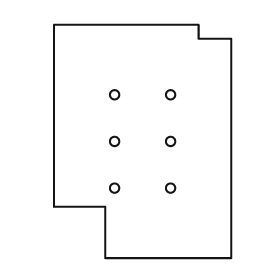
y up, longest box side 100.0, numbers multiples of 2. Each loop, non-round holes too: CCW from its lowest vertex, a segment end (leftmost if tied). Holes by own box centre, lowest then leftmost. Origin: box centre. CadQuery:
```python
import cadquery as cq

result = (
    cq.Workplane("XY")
    .moveTo(-16.0, -50.0)
    .lineTo(38.0, -50.0)
    .lineTo(38.0, 44.0)
    .lineTo(24.0, 44.0)
    .lineTo(24.0, 50.0)
    .lineTo(-38.0, 50.0)
    .lineTo(-38.0, -28.0)
    .lineTo(-16.0, -28.0)
    .close()
    .moveTo(-12.0, -20.0)
    .circle(2.0)
    .moveTo(12.0, -20.0)
    .circle(2.0)
    .moveTo(-12.0, 0.0)
    .circle(2.0)
    .moveTo(12.0, 0.0)
    .circle(2.0)
    .moveTo(-12.0, 20.0)
    .circle(2.0)
    .moveTo(12.0, 20.0)
    .circle(2.0)
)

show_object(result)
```